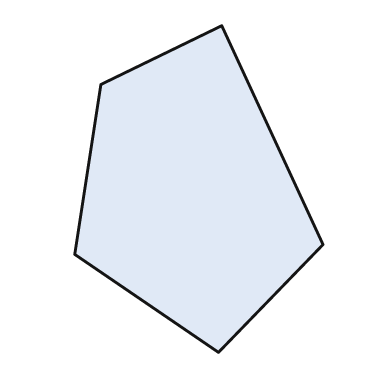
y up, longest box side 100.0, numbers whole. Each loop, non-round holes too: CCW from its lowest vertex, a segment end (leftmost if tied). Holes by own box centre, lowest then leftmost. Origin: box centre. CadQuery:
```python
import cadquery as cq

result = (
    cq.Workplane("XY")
    .moveTo(6.0, -50.0)
    .lineTo(38.0, -17.0)
    .lineTo(7.0, 50.0)
    .lineTo(-30.0, 32.0)
    .lineTo(-38.0, -20.0)
    .close()
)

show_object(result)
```